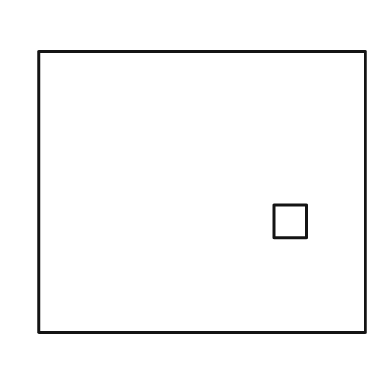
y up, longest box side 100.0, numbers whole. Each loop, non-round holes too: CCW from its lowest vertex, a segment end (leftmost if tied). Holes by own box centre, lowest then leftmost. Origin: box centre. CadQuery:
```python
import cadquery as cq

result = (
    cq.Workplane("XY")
    .moveTo(-50.0, -43.0)
    .lineTo(50.0, -43.0)
    .lineTo(50.0, 43.0)
    .lineTo(-50.0, 43.0)
    .close()
    .moveTo(22.0, -14.0)
    .lineTo(32.0, -14.0)
    .lineTo(32.0, -4.0)
    .lineTo(22.0, -4.0)
    .close()
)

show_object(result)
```